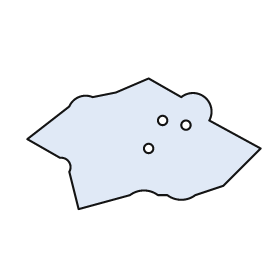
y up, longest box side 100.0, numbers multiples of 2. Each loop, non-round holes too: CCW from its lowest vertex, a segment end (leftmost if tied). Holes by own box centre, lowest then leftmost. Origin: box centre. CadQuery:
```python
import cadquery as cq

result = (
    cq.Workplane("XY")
    .moveTo(-28.0, -28.0)
    .lineTo(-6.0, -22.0)
    .threePointArc((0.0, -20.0), (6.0, -22.0))
    .lineTo(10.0, -22.0)
    .threePointArc((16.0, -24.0), (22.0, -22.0))
    .lineTo(34.0, -18.0)
    .lineTo(50.0, -2.0)
    .lineTo(28.0, 10.0)
    .threePointArc((26.0, 20.0), (16.0, 20.0))
    .lineTo(2.0, 28.0)
    .lineTo(-12.0, 22.0)
    .lineTo(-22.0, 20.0)
    .threePointArc((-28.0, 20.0), (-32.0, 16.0))
    .lineTo(-50.0, 2.0)
    .lineTo(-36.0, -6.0)
    .threePointArc((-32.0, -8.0), (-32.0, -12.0))
    .close()
    .moveTo(2.0, -2.0)
    .circle(2.0)
    .moveTo(18.0, 8.0)
    .circle(2.0)
    .moveTo(8.0, 10.0)
    .circle(2.0)
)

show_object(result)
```